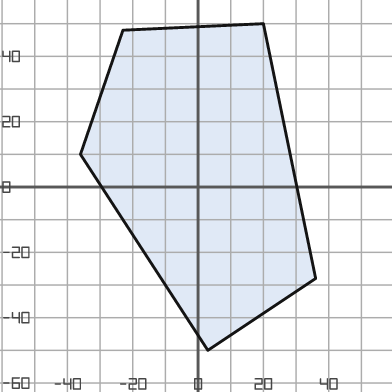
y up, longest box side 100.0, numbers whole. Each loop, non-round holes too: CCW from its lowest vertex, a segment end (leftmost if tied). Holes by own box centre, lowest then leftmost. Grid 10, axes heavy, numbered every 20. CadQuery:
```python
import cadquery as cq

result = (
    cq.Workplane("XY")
    .moveTo(3.0, -50.0)
    .lineTo(36.0, -28.0)
    .lineTo(20.0, 50.0)
    .lineTo(-23.0, 48.0)
    .lineTo(-36.0, 10.0)
    .close()
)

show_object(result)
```